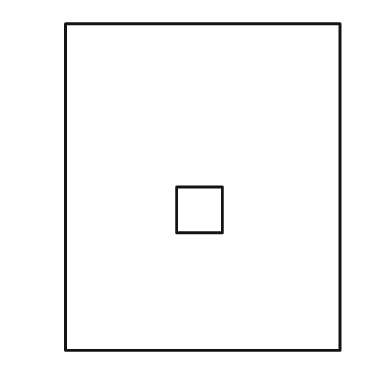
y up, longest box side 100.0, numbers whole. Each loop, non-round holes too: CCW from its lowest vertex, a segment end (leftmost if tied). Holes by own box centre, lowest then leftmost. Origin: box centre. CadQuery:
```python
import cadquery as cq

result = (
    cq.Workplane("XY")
    .moveTo(-42.0, -50.0)
    .lineTo(42.0, -50.0)
    .lineTo(42.0, 50.0)
    .lineTo(-42.0, 50.0)
    .close()
    .moveTo(-8.0, -14.0)
    .lineTo(6.0, -14.0)
    .lineTo(6.0, 0.0)
    .lineTo(-8.0, 0.0)
    .close()
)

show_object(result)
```